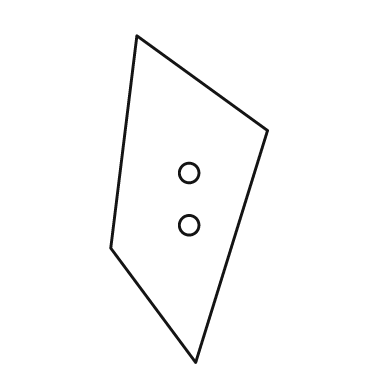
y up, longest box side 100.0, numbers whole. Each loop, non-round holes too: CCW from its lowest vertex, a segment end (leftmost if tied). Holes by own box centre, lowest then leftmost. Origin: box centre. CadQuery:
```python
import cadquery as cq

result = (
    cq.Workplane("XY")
    .moveTo(2.0, -50.0)
    .lineTo(24.0, 21.0)
    .lineTo(-16.0, 50.0)
    .lineTo(-24.0, -15.0)
    .close()
    .moveTo(0.0, -8.0)
    .circle(3.0)
    .moveTo(0.0, 8.0)
    .circle(3.0)
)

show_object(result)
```